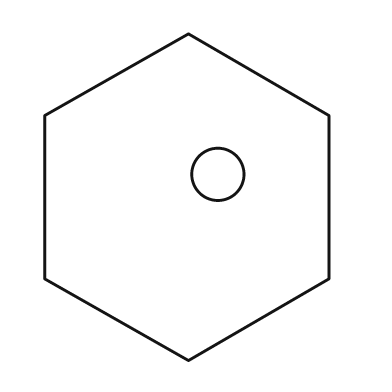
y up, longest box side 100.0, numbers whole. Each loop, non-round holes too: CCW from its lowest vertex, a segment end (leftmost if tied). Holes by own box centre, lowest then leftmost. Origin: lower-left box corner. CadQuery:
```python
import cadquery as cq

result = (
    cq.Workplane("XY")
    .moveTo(44.0, 0.0)
    .lineTo(87.0, 25.0)
    .lineTo(87.0, 75.0)
    .lineTo(44.0, 100.0)
    .lineTo(0.0, 75.0)
    .lineTo(0.0, 25.0)
    .close()
    .moveTo(53.0, 57.0)
    .circle(8.0)
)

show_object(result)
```